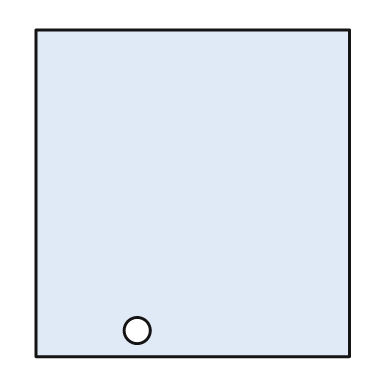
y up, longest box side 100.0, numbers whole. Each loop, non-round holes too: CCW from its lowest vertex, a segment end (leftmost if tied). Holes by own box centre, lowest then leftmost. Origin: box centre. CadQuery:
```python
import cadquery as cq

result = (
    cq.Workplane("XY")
    .moveTo(-48.0, -50.0)
    .lineTo(48.0, -50.0)
    .lineTo(48.0, 50.0)
    .lineTo(-48.0, 50.0)
    .close()
    .moveTo(-17.0, -42.0)
    .circle(4.0)
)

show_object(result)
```